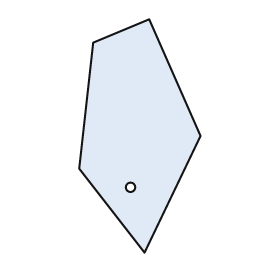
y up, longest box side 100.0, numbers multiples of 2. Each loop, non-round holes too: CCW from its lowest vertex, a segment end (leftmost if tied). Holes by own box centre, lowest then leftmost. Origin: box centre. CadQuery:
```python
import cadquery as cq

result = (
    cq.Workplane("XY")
    .moveTo(2.0, -50.0)
    .lineTo(26.0, 0.0)
    .lineTo(4.0, 50.0)
    .lineTo(-20.0, 40.0)
    .lineTo(-26.0, -14.0)
    .close()
    .moveTo(-4.0, -22.0)
    .circle(2.0)
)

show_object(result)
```